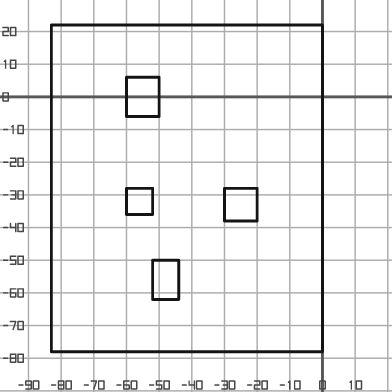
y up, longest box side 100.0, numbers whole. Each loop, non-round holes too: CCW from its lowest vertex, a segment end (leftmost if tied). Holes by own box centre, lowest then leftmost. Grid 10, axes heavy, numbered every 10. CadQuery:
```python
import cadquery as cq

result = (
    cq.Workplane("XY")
    .moveTo(-83.0, -78.0)
    .lineTo(0.0, -78.0)
    .lineTo(0.0, 22.0)
    .lineTo(-83.0, 22.0)
    .close()
    .moveTo(-52.0, -62.0)
    .lineTo(-44.0, -62.0)
    .lineTo(-44.0, -50.0)
    .lineTo(-52.0, -50.0)
    .close()
    .moveTo(-30.0, -38.0)
    .lineTo(-20.0, -38.0)
    .lineTo(-20.0, -28.0)
    .lineTo(-30.0, -28.0)
    .close()
    .moveTo(-60.0, -36.0)
    .lineTo(-52.0, -36.0)
    .lineTo(-52.0, -28.0)
    .lineTo(-60.0, -28.0)
    .close()
    .moveTo(-60.0, -6.0)
    .lineTo(-50.0, -6.0)
    .lineTo(-50.0, 6.0)
    .lineTo(-60.0, 6.0)
    .close()
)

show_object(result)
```